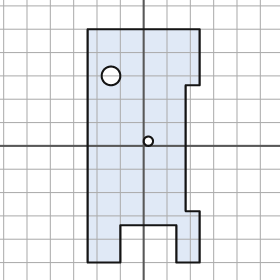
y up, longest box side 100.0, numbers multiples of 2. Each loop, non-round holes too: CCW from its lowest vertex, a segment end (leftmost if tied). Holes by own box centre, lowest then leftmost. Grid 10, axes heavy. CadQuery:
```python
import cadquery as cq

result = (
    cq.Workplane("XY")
    .moveTo(-24.0, -50.0)
    .lineTo(-10.0, -50.0)
    .lineTo(-10.0, -34.0)
    .lineTo(14.0, -34.0)
    .lineTo(14.0, -50.0)
    .lineTo(24.0, -50.0)
    .lineTo(24.0, -28.0)
    .lineTo(18.0, -28.0)
    .lineTo(18.0, 26.0)
    .lineTo(24.0, 26.0)
    .lineTo(24.0, 50.0)
    .lineTo(-24.0, 50.0)
    .close()
    .moveTo(2.0, 2.0)
    .circle(2.0)
    .moveTo(-14.0, 30.0)
    .circle(4.0)
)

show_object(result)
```